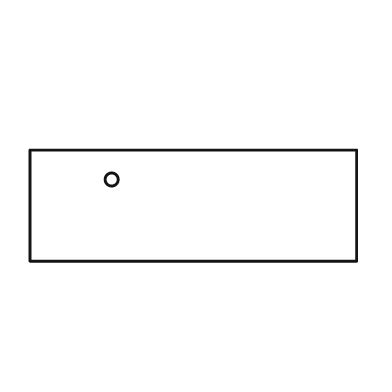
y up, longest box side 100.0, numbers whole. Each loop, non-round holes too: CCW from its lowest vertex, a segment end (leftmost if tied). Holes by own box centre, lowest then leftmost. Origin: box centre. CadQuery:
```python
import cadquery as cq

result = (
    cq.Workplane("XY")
    .moveTo(-50.0, -17.0)
    .lineTo(50.0, -17.0)
    .lineTo(50.0, 17.0)
    .lineTo(-50.0, 17.0)
    .close()
    .moveTo(-25.0, 8.0)
    .circle(2.0)
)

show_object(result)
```